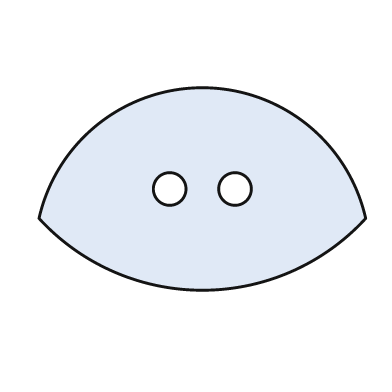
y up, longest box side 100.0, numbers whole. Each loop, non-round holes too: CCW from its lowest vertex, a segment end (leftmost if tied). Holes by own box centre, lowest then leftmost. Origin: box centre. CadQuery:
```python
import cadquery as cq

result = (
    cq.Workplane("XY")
    .moveTo(-50.0, -9.0)
    .threePointArc((0.0, -31.0), (50.0, -9.0))
    .threePointArc((0.0, 31.0), (-50.0, -9.0))
    .close()
    .moveTo(-10.0, 0.0)
    .circle(5.0)
    .moveTo(10.0, 0.0)
    .circle(5.0)
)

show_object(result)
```